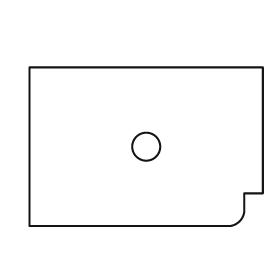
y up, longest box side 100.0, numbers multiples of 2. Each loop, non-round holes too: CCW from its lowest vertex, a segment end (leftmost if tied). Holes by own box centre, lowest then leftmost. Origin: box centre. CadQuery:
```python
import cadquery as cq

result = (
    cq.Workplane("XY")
    .moveTo(-50.0, -34.0)
    .lineTo(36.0, -34.0)
    .threePointArc((40.0, -32.0), (42.0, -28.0))
    .lineTo(42.0, -20.0)
    .lineTo(50.0, -20.0)
    .lineTo(50.0, 34.0)
    .lineTo(-50.0, 34.0)
    .close()
    .moveTo(0.0, 0.0)
    .circle(6.0)
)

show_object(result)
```